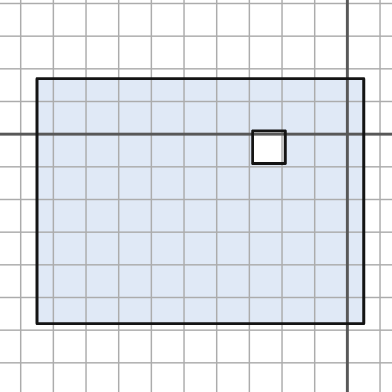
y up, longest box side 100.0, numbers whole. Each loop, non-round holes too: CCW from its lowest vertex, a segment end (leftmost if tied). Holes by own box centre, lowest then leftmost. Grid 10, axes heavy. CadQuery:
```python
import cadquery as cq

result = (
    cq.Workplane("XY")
    .moveTo(-95.0, -58.0)
    .lineTo(5.0, -58.0)
    .lineTo(5.0, 17.0)
    .lineTo(-95.0, 17.0)
    .close()
    .moveTo(-29.0, -9.0)
    .lineTo(-19.0, -9.0)
    .lineTo(-19.0, 1.0)
    .lineTo(-29.0, 1.0)
    .close()
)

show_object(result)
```